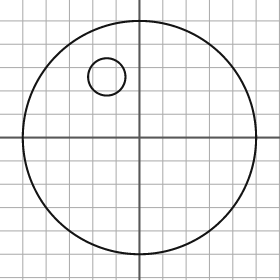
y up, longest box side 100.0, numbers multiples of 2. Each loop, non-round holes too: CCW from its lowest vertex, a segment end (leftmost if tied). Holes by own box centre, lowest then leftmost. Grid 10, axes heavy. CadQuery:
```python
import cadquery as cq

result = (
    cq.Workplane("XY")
    .moveTo(0.0, 0.0)
    .circle(50.0)
    .moveTo(-14.0, 26.0)
    .circle(8.0)
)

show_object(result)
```